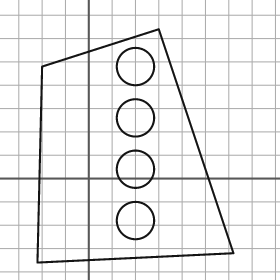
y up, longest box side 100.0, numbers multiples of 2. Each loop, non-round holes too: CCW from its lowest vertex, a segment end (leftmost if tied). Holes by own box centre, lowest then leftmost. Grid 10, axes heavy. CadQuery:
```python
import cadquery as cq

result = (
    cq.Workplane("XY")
    .moveTo(-22.0, -36.0)
    .lineTo(62.0, -32.0)
    .lineTo(30.0, 64.0)
    .lineTo(-20.0, 48.0)
    .close()
    .moveTo(20.0, -18.0)
    .circle(8.0)
    .moveTo(20.0, 4.0)
    .circle(8.0)
    .moveTo(20.0, 26.0)
    .circle(8.0)
    .moveTo(20.0, 48.0)
    .circle(8.0)
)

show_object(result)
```